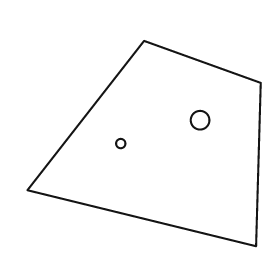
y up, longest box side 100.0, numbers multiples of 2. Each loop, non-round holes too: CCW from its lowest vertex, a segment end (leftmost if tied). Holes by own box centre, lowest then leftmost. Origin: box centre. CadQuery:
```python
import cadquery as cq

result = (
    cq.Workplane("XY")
    .moveTo(48.0, -44.0)
    .lineTo(50.0, 26.0)
    .lineTo(0.0, 44.0)
    .lineTo(-50.0, -20.0)
    .close()
    .moveTo(-10.0, 0.0)
    .circle(2.0)
    .moveTo(24.0, 10.0)
    .circle(4.0)
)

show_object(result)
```